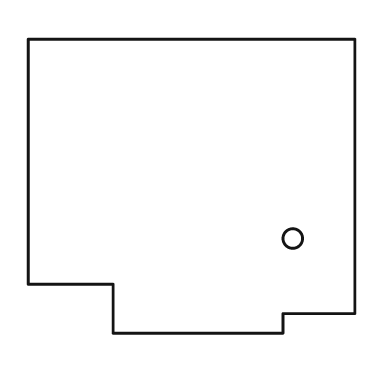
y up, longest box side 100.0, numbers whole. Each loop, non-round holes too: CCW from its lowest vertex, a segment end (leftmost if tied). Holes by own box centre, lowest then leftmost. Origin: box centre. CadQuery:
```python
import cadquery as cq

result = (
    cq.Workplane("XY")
    .moveTo(-24.0, -45.0)
    .lineTo(28.0, -45.0)
    .lineTo(28.0, -39.0)
    .lineTo(50.0, -39.0)
    .lineTo(50.0, 45.0)
    .lineTo(-50.0, 45.0)
    .lineTo(-50.0, -30.0)
    .lineTo(-24.0, -30.0)
    .close()
    .moveTo(31.0, -16.0)
    .circle(3.0)
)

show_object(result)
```